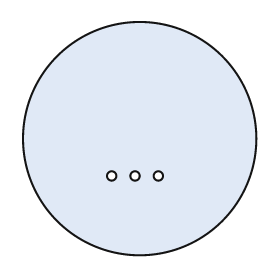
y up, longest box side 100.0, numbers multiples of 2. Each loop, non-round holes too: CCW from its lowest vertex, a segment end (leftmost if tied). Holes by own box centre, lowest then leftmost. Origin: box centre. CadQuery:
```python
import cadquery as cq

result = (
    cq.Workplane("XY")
    .moveTo(0.0, 0.0)
    .circle(50.0)
    .moveTo(-12.0, -16.0)
    .circle(2.0)
    .moveTo(-2.0, -16.0)
    .circle(2.0)
    .moveTo(8.0, -16.0)
    .circle(2.0)
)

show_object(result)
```